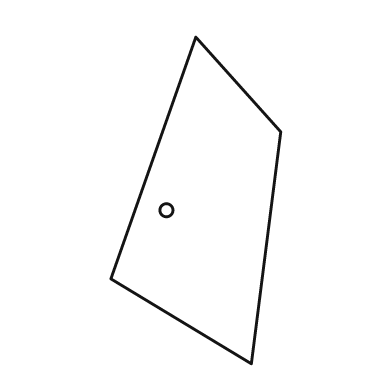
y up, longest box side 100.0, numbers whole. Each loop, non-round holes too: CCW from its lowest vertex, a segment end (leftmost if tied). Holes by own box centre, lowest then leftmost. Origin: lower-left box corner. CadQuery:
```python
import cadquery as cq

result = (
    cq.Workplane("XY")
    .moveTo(43.0, 0.0)
    .lineTo(52.0, 71.0)
    .lineTo(26.0, 100.0)
    .lineTo(0.0, 26.0)
    .close()
    .moveTo(17.0, 47.0)
    .circle(2.0)
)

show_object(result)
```